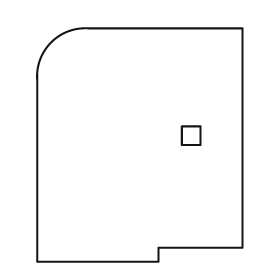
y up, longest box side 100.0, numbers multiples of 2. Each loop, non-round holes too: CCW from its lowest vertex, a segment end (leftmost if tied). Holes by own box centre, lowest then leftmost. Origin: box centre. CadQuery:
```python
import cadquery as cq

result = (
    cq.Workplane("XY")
    .moveTo(-44.0, -50.0)
    .lineTo(8.0, -50.0)
    .lineTo(8.0, -44.0)
    .lineTo(44.0, -44.0)
    .lineTo(44.0, 50.0)
    .lineTo(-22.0, 50.0)
    .threePointArc((-38.0, 44.0), (-44.0, 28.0))
    .close()
    .moveTo(18.0, 0.0)
    .lineTo(26.0, 0.0)
    .lineTo(26.0, 8.0)
    .lineTo(18.0, 8.0)
    .close()
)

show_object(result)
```